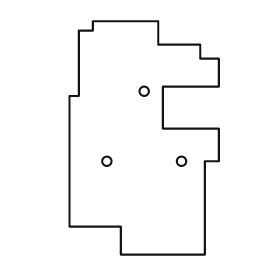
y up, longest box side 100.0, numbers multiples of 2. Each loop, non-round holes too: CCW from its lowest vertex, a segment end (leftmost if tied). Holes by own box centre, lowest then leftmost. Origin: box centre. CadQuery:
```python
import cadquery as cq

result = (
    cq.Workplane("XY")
    .moveTo(-10.0, -50.0)
    .lineTo(26.0, -50.0)
    .lineTo(26.0, -10.0)
    .lineTo(32.0, -10.0)
    .lineTo(32.0, 4.0)
    .lineTo(8.0, 4.0)
    .lineTo(8.0, 22.0)
    .lineTo(32.0, 22.0)
    .lineTo(32.0, 34.0)
    .lineTo(24.0, 34.0)
    .lineTo(24.0, 40.0)
    .lineTo(6.0, 40.0)
    .lineTo(6.0, 50.0)
    .lineTo(-22.0, 50.0)
    .lineTo(-22.0, 46.0)
    .lineTo(-28.0, 46.0)
    .lineTo(-28.0, 18.0)
    .lineTo(-32.0, 18.0)
    .lineTo(-32.0, -38.0)
    .lineTo(-10.0, -38.0)
    .close()
    .moveTo(-16.0, -10.0)
    .circle(2.0)
    .moveTo(16.0, -10.0)
    .circle(2.0)
    .moveTo(0.0, 20.0)
    .circle(2.0)
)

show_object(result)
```